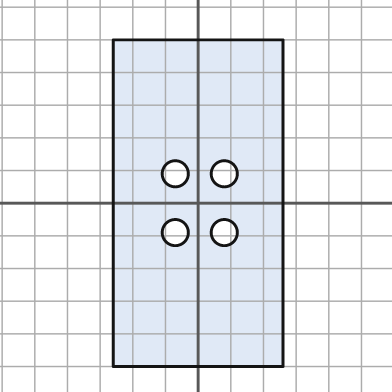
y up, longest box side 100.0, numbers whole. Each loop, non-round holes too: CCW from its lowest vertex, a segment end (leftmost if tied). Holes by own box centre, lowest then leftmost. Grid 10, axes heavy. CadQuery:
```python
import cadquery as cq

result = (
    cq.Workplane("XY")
    .moveTo(-26.0, -50.0)
    .lineTo(26.0, -50.0)
    .lineTo(26.0, 50.0)
    .lineTo(-26.0, 50.0)
    .close()
    .moveTo(-7.0, -9.0)
    .circle(4.0)
    .moveTo(8.0, -9.0)
    .circle(4.0)
    .moveTo(-7.0, 9.0)
    .circle(4.0)
    .moveTo(8.0, 9.0)
    .circle(4.0)
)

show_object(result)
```